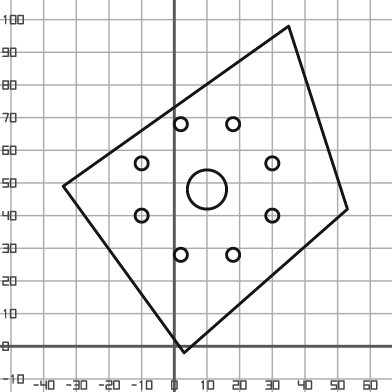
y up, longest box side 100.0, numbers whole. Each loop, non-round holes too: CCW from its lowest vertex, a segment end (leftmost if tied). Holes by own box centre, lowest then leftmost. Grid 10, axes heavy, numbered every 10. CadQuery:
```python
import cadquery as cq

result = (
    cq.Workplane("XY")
    .moveTo(3.0, -2.0)
    .lineTo(53.0, 42.0)
    .lineTo(35.0, 98.0)
    .lineTo(-34.0, 49.0)
    .close()
    .moveTo(2.0, 28.0)
    .circle(2.0)
    .moveTo(18.0, 28.0)
    .circle(2.0)
    .moveTo(-10.0, 40.0)
    .circle(2.0)
    .moveTo(30.0, 40.0)
    .circle(2.0)
    .moveTo(10.0, 48.0)
    .circle(6.0)
    .moveTo(-10.0, 56.0)
    .circle(2.0)
    .moveTo(30.0, 56.0)
    .circle(2.0)
    .moveTo(2.0, 68.0)
    .circle(2.0)
    .moveTo(18.0, 68.0)
    .circle(2.0)
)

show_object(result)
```